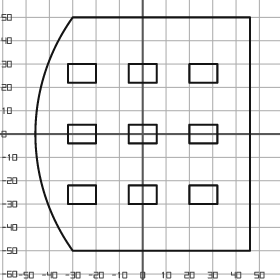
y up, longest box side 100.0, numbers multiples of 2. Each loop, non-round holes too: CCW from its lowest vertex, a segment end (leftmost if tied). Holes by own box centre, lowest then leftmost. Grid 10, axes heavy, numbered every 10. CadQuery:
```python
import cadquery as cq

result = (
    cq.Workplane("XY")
    .moveTo(-30.0, -50.0)
    .lineTo(46.0, -50.0)
    .lineTo(46.0, 50.0)
    .lineTo(-30.0, 50.0)
    .threePointArc((-46.0, 0.0), (-30.0, -50.0))
    .close()
    .moveTo(-32.0, -30.0)
    .lineTo(-20.0, -30.0)
    .lineTo(-20.0, -22.0)
    .lineTo(-32.0, -22.0)
    .close()
    .moveTo(-6.0, -30.0)
    .lineTo(6.0, -30.0)
    .lineTo(6.0, -22.0)
    .lineTo(-6.0, -22.0)
    .close()
    .moveTo(20.0, -30.0)
    .lineTo(32.0, -30.0)
    .lineTo(32.0, -22.0)
    .lineTo(20.0, -22.0)
    .close()
    .moveTo(-32.0, -4.0)
    .lineTo(-20.0, -4.0)
    .lineTo(-20.0, 4.0)
    .lineTo(-32.0, 4.0)
    .close()
    .moveTo(-6.0, -4.0)
    .lineTo(6.0, -4.0)
    .lineTo(6.0, 4.0)
    .lineTo(-6.0, 4.0)
    .close()
    .moveTo(20.0, -4.0)
    .lineTo(32.0, -4.0)
    .lineTo(32.0, 4.0)
    .lineTo(20.0, 4.0)
    .close()
    .moveTo(-32.0, 22.0)
    .lineTo(-20.0, 22.0)
    .lineTo(-20.0, 30.0)
    .lineTo(-32.0, 30.0)
    .close()
    .moveTo(-6.0, 22.0)
    .lineTo(6.0, 22.0)
    .lineTo(6.0, 30.0)
    .lineTo(-6.0, 30.0)
    .close()
    .moveTo(20.0, 22.0)
    .lineTo(32.0, 22.0)
    .lineTo(32.0, 30.0)
    .lineTo(20.0, 30.0)
    .close()
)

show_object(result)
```